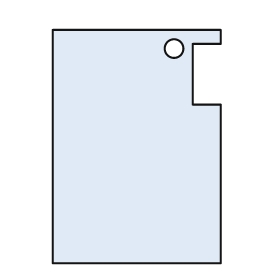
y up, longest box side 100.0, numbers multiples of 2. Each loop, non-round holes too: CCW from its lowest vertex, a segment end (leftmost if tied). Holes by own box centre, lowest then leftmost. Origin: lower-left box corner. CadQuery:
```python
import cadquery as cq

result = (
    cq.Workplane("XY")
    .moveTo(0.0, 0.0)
    .lineTo(72.0, 0.0)
    .lineTo(72.0, 68.0)
    .lineTo(60.0, 68.0)
    .lineTo(60.0, 94.0)
    .lineTo(72.0, 94.0)
    .lineTo(72.0, 100.0)
    .lineTo(0.0, 100.0)
    .close()
    .moveTo(52.0, 92.0)
    .circle(4.0)
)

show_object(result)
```